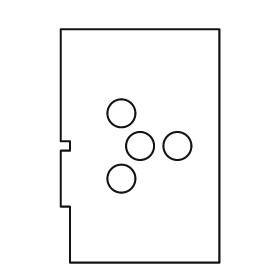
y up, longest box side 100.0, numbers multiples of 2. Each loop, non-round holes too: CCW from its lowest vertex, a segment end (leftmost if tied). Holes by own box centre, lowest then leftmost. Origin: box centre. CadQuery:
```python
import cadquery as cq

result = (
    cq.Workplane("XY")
    .moveTo(-30.0, -50.0)
    .lineTo(34.0, -50.0)
    .lineTo(34.0, 50.0)
    .lineTo(-34.0, 50.0)
    .lineTo(-34.0, 2.0)
    .lineTo(-30.0, 2.0)
    .lineTo(-30.0, -2.0)
    .lineTo(-34.0, -2.0)
    .lineTo(-34.0, -26.0)
    .lineTo(-30.0, -26.0)
    .close()
    .moveTo(-8.0, -14.0)
    .circle(6.0)
    .moveTo(0.0, 0.0)
    .circle(6.0)
    .moveTo(16.0, 0.0)
    .circle(6.0)
    .moveTo(-8.0, 14.0)
    .circle(6.0)
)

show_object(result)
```